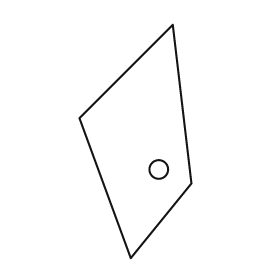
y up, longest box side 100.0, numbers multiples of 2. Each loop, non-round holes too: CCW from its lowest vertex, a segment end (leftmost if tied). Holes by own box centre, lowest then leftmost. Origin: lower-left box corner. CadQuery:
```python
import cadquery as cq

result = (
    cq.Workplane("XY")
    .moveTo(22.0, 0.0)
    .lineTo(48.0, 32.0)
    .lineTo(40.0, 100.0)
    .lineTo(0.0, 60.0)
    .close()
    .moveTo(34.0, 38.0)
    .circle(4.0)
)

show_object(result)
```